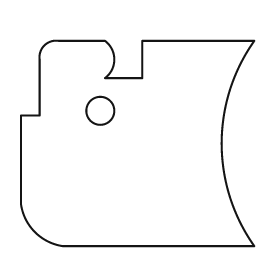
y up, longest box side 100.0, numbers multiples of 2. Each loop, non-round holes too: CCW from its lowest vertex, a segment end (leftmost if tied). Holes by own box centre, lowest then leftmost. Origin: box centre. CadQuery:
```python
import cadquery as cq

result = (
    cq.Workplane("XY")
    .moveTo(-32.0, -44.0)
    .lineTo(50.0, -44.0)
    .threePointArc((36.0, 0.0), (50.0, 44.0))
    .lineTo(2.0, 44.0)
    .lineTo(2.0, 28.0)
    .lineTo(-14.0, 28.0)
    .threePointArc((-10.0, 36.0), (-14.0, 44.0))
    .lineTo(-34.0, 44.0)
    .threePointArc((-40.0, 42.0), (-42.0, 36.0))
    .lineTo(-42.0, 12.0)
    .lineTo(-50.0, 12.0)
    .lineTo(-50.0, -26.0)
    .threePointArc((-44.0, -38.0), (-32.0, -44.0))
    .close()
    .moveTo(-16.0, 14.0)
    .circle(6.0)
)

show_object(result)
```